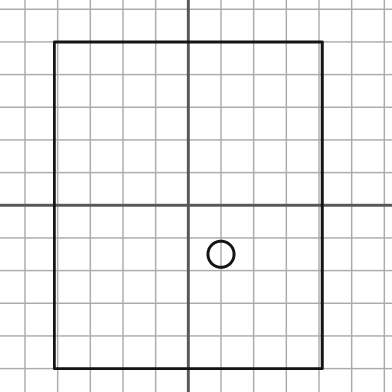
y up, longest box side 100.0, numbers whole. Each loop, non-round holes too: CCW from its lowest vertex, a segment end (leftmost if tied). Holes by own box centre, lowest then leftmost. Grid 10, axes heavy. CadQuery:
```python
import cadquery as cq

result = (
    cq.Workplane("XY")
    .moveTo(-41.0, -50.0)
    .lineTo(41.0, -50.0)
    .lineTo(41.0, 50.0)
    .lineTo(-41.0, 50.0)
    .close()
    .moveTo(10.0, -15.0)
    .circle(4.0)
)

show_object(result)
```